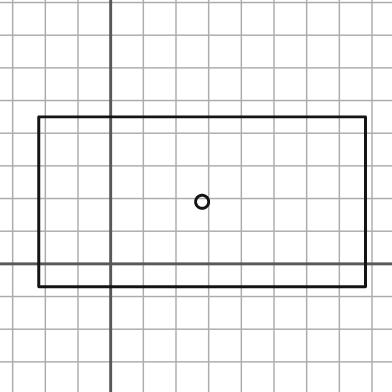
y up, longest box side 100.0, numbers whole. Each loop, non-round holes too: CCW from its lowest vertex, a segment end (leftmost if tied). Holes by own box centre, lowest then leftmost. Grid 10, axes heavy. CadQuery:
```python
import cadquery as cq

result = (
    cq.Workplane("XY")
    .moveTo(-22.0, -7.0)
    .lineTo(78.0, -7.0)
    .lineTo(78.0, 45.0)
    .lineTo(-22.0, 45.0)
    .close()
    .moveTo(28.0, 19.0)
    .circle(2.0)
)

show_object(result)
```